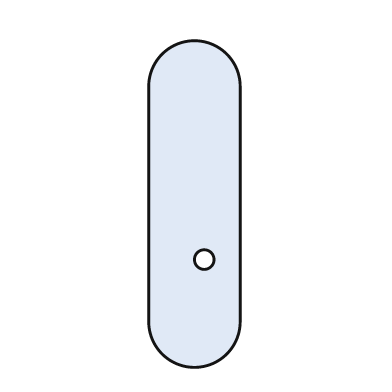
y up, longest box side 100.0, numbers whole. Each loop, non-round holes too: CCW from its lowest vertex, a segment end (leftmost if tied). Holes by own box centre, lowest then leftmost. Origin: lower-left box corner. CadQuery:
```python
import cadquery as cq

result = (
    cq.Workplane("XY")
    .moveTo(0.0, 14.0)
    .threePointArc((14.0, 0.0), (28.0, 14.0))
    .lineTo(28.0, 86.0)
    .threePointArc((14.0, 100.0), (0.0, 86.0))
    .close()
    .moveTo(17.0, 33.0)
    .circle(3.0)
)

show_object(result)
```